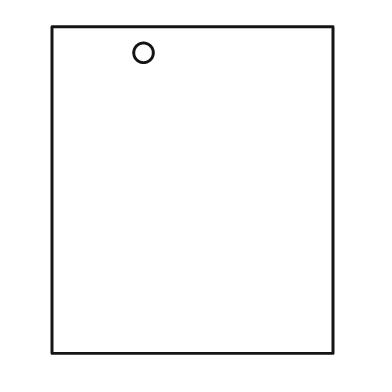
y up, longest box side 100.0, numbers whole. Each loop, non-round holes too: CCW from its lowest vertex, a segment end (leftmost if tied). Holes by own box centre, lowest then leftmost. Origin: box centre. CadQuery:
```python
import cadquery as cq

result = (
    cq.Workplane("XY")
    .moveTo(-43.0, -50.0)
    .lineTo(43.0, -50.0)
    .lineTo(43.0, 50.0)
    .lineTo(-43.0, 50.0)
    .close()
    .moveTo(-15.0, 42.0)
    .circle(3.0)
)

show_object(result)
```